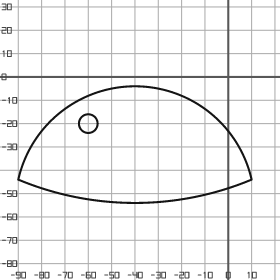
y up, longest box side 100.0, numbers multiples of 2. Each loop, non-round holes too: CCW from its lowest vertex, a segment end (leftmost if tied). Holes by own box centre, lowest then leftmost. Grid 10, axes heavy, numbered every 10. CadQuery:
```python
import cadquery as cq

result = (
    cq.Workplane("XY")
    .moveTo(-90.0, -44.0)
    .threePointArc((-40.0, -54.0), (10.0, -44.0))
    .threePointArc((-40.0, -4.0), (-90.0, -44.0))
    .close()
    .moveTo(-60.0, -20.0)
    .circle(4.0)
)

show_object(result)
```